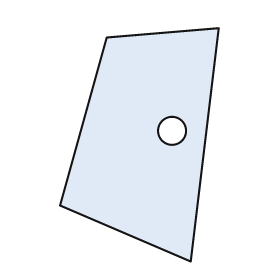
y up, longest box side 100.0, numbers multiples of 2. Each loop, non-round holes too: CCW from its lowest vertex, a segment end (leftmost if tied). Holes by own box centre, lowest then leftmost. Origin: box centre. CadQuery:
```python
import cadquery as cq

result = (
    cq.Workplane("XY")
    .moveTo(22.0, -50.0)
    .lineTo(34.0, 50.0)
    .lineTo(-14.0, 46.0)
    .lineTo(-34.0, -26.0)
    .close()
    .moveTo(14.0, 6.0)
    .circle(6.0)
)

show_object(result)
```